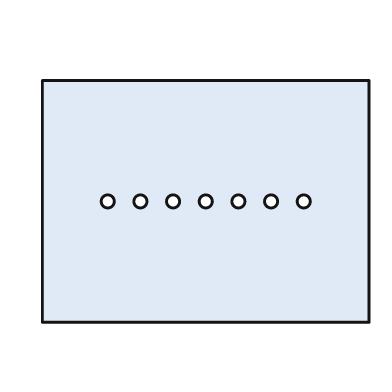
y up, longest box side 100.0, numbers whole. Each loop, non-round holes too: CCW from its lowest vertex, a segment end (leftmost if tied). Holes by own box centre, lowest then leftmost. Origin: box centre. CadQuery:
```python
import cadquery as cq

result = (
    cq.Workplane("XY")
    .moveTo(-50.0, -37.0)
    .lineTo(50.0, -37.0)
    .lineTo(50.0, 37.0)
    .lineTo(-50.0, 37.0)
    .close()
    .moveTo(-30.0, 0.0)
    .circle(2.0)
    .moveTo(-20.0, 0.0)
    .circle(2.0)
    .moveTo(-10.0, 0.0)
    .circle(2.0)
    .moveTo(0.0, 0.0)
    .circle(2.0)
    .moveTo(10.0, 0.0)
    .circle(2.0)
    .moveTo(20.0, 0.0)
    .circle(2.0)
    .moveTo(30.0, 0.0)
    .circle(2.0)
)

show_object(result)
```